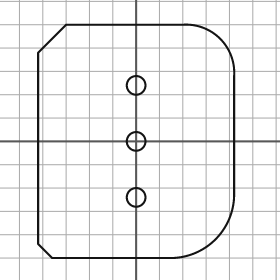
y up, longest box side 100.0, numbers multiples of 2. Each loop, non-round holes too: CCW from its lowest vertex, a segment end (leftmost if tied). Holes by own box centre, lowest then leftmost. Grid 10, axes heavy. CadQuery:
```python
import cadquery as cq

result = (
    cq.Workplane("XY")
    .moveTo(-36.0, -50.0)
    .lineTo(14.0, -50.0)
    .threePointArc((34.0, -42.0), (42.0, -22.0))
    .lineTo(42.0, 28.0)
    .threePointArc((36.0, 44.0), (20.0, 50.0))
    .lineTo(-30.0, 50.0)
    .lineTo(-42.0, 38.0)
    .lineTo(-42.0, -44.0)
    .close()
    .moveTo(0.0, -24.0)
    .circle(4.0)
    .moveTo(0.0, 0.0)
    .circle(4.0)
    .moveTo(0.0, 24.0)
    .circle(4.0)
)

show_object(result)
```